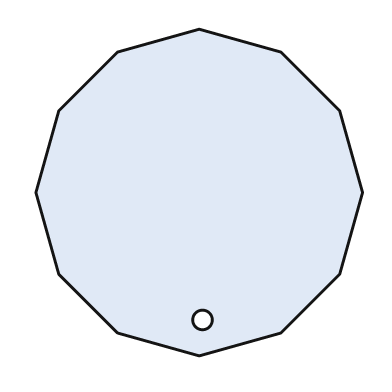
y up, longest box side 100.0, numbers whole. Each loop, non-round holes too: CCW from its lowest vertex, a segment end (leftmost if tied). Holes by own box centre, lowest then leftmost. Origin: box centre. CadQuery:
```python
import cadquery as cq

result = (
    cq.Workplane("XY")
    .moveTo(0.0, -50.0)
    .lineTo(25.0, -43.0)
    .lineTo(43.0, -25.0)
    .lineTo(50.0, 0.0)
    .lineTo(43.0, 25.0)
    .lineTo(25.0, 43.0)
    .lineTo(0.0, 50.0)
    .lineTo(-25.0, 43.0)
    .lineTo(-43.0, 25.0)
    .lineTo(-50.0, 0.0)
    .lineTo(-43.0, -25.0)
    .lineTo(-25.0, -43.0)
    .close()
    .moveTo(1.0, -39.0)
    .circle(3.0)
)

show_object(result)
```